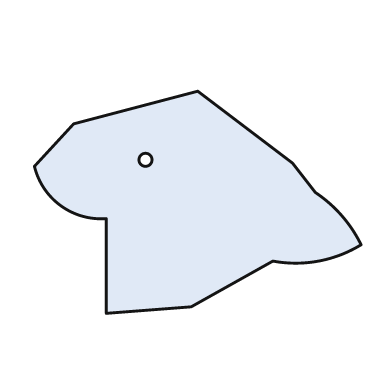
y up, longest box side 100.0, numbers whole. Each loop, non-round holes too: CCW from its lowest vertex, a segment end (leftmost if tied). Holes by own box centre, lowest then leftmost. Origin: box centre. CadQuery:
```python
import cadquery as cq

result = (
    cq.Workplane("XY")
    .moveTo(-28.0, -34.0)
    .lineTo(-2.0, -32.0)
    .lineTo(23.0, -18.0)
    .threePointArc((37.0, -18.0), (50.0, -13.0))
    .threePointArc((44.0, -4.0), (36.0, 3.0))
    .lineTo(29.0, 12.0)
    .lineTo(0.0, 34.0)
    .lineTo(-38.0, 24.0)
    .lineTo(-50.0, 11.0)
    .threePointArc((-42.0, -1.0), (-28.0, -5.0))
    .close()
    .moveTo(-16.0, 13.0)
    .circle(2.0)
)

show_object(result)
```